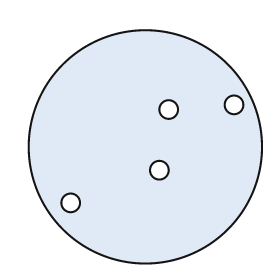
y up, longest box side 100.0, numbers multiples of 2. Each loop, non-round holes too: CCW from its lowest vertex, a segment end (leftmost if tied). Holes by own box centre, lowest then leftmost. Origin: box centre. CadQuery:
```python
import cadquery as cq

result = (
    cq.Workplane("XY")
    .moveTo(0.0, 0.0)
    .circle(50.0)
    .moveTo(-32.0, -24.0)
    .circle(4.0)
    .moveTo(6.0, -10.0)
    .circle(4.0)
    .moveTo(10.0, 16.0)
    .circle(4.0)
    .moveTo(38.0, 18.0)
    .circle(4.0)
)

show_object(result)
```